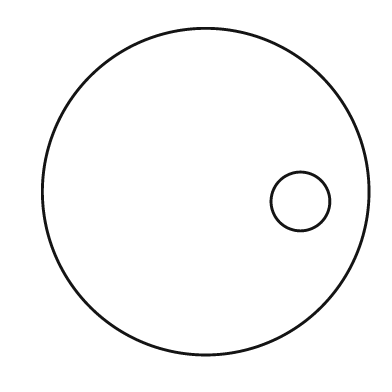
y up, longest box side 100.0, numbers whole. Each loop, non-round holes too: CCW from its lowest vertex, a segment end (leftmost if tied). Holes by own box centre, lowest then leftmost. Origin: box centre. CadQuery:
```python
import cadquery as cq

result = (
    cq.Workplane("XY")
    .moveTo(0.0, 0.0)
    .circle(50.0)
    .moveTo(29.0, -3.0)
    .circle(9.0)
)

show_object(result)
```